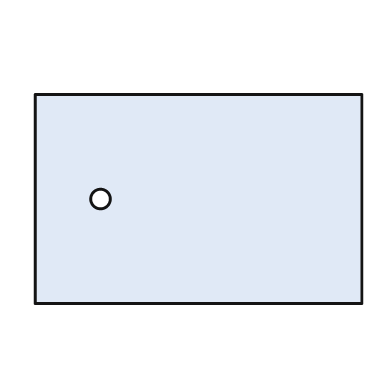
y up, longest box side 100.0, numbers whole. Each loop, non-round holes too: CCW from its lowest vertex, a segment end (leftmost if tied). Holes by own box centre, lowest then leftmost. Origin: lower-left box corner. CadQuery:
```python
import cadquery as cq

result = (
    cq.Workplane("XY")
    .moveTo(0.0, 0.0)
    .lineTo(100.0, 0.0)
    .lineTo(100.0, 64.0)
    .lineTo(0.0, 64.0)
    .close()
    .moveTo(20.0, 32.0)
    .circle(3.0)
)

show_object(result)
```